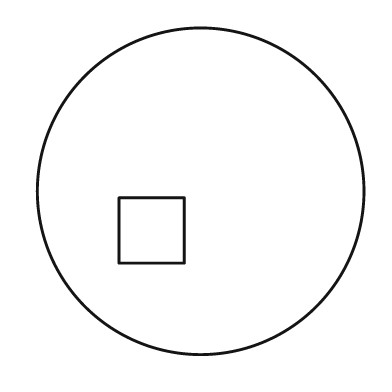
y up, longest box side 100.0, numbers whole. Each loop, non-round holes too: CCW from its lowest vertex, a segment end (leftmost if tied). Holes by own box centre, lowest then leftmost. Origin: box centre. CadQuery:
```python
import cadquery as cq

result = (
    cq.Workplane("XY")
    .moveTo(0.0, 0.0)
    .circle(50.0)
    .moveTo(-25.0, -22.0)
    .lineTo(-5.0, -22.0)
    .lineTo(-5.0, -2.0)
    .lineTo(-25.0, -2.0)
    .close()
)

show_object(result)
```